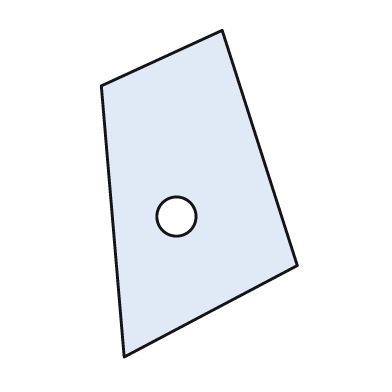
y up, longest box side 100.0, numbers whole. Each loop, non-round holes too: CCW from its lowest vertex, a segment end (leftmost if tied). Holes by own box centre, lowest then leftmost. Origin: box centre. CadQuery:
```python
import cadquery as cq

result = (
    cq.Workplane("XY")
    .moveTo(-23.0, -50.0)
    .lineTo(30.0, -22.0)
    .lineTo(7.0, 50.0)
    .lineTo(-30.0, 33.0)
    .close()
    .moveTo(-7.0, -7.0)
    .circle(6.0)
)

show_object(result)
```